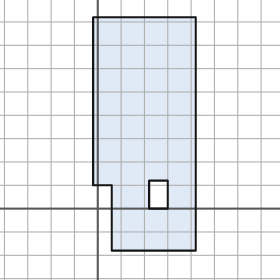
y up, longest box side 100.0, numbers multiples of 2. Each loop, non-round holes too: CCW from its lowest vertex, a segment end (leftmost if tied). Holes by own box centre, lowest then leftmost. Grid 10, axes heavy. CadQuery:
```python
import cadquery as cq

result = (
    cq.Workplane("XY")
    .moveTo(6.0, -18.0)
    .lineTo(42.0, -18.0)
    .lineTo(42.0, 82.0)
    .lineTo(-2.0, 82.0)
    .lineTo(-2.0, 10.0)
    .lineTo(6.0, 10.0)
    .close()
    .moveTo(22.0, 0.0)
    .lineTo(30.0, 0.0)
    .lineTo(30.0, 12.0)
    .lineTo(22.0, 12.0)
    .close()
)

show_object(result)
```